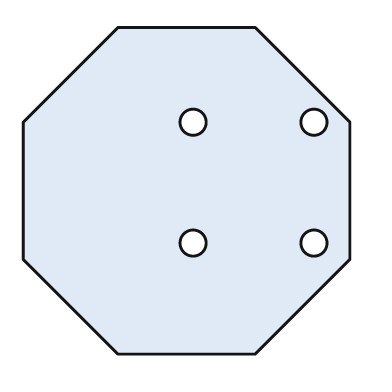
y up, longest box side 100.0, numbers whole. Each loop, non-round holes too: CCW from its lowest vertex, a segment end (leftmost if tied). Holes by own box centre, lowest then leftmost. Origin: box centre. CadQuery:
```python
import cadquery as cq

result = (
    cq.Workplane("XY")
    .moveTo(-21.0, -50.0)
    .lineTo(21.0, -50.0)
    .lineTo(50.0, -21.0)
    .lineTo(50.0, 21.0)
    .lineTo(21.0, 50.0)
    .lineTo(-21.0, 50.0)
    .lineTo(-50.0, 21.0)
    .lineTo(-50.0, -21.0)
    .close()
    .moveTo(2.0, -16.0)
    .circle(4.0)
    .moveTo(39.0, -16.0)
    .circle(4.0)
    .moveTo(2.0, 21.0)
    .circle(4.0)
    .moveTo(39.0, 21.0)
    .circle(4.0)
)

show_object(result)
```